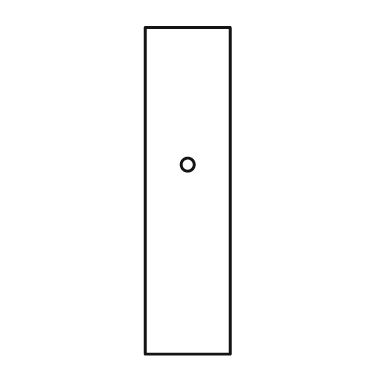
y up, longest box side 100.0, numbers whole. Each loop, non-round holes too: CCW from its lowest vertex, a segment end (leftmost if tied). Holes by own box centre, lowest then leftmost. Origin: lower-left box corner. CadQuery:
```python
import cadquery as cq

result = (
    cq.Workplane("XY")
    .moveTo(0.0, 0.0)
    .lineTo(26.0, 0.0)
    .lineTo(26.0, 100.0)
    .lineTo(0.0, 100.0)
    .close()
    .moveTo(13.0, 58.0)
    .circle(2.0)
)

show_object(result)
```